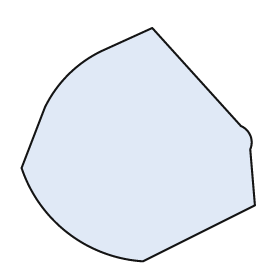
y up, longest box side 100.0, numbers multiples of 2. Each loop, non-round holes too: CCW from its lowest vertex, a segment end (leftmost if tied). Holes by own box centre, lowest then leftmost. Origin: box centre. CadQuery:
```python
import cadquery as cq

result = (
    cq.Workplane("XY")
    .moveTo(2.0, -50.0)
    .lineTo(50.0, -26.0)
    .lineTo(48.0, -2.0)
    .threePointArc((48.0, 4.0), (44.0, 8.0))
    .lineTo(6.0, 50.0)
    .lineTo(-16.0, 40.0)
    .threePointArc((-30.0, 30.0), (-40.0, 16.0))
    .lineTo(-50.0, -10.0)
    .threePointArc((-30.0, -38.0), (2.0, -50.0))
    .close()
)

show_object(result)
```